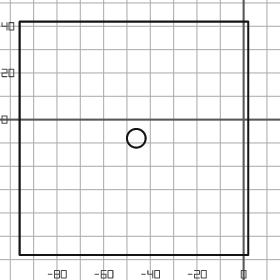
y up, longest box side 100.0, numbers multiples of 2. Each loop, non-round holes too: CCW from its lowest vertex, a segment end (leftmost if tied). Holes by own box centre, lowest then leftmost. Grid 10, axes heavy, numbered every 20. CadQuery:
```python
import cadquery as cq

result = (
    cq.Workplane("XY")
    .moveTo(-96.0, -58.0)
    .lineTo(2.0, -58.0)
    .lineTo(2.0, 42.0)
    .lineTo(-96.0, 42.0)
    .close()
    .moveTo(-46.0, -8.0)
    .circle(4.0)
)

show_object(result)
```